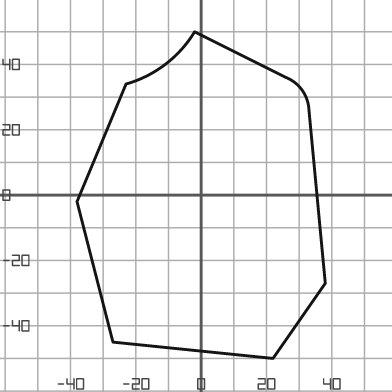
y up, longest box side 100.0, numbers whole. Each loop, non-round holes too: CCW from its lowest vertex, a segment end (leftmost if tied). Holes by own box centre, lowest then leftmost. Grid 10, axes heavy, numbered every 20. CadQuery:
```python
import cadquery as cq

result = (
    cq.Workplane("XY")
    .moveTo(22.0, -50.0)
    .lineTo(38.0, -27.0)
    .lineTo(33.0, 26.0)
    .threePointArc((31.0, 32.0), (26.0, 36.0))
    .lineTo(-2.0, 50.0)
    .threePointArc((-11.0, 40.0), (-23.0, 34.0))
    .lineTo(-38.0, -2.0)
    .lineTo(-27.0, -45.0)
    .close()
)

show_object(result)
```